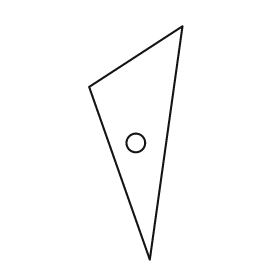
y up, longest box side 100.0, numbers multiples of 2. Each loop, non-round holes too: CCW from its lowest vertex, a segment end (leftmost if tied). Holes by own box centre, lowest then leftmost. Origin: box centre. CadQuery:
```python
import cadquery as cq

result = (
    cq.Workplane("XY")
    .moveTo(6.0, -50.0)
    .lineTo(20.0, 50.0)
    .lineTo(-20.0, 24.0)
    .close()
    .moveTo(0.0, 0.0)
    .circle(4.0)
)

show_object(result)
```